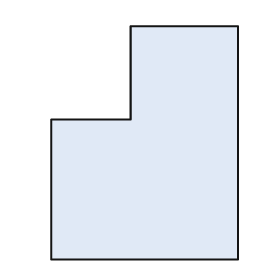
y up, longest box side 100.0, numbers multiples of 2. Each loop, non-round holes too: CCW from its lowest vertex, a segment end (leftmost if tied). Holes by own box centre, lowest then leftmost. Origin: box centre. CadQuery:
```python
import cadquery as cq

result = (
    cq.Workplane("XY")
    .moveTo(-40.0, -50.0)
    .lineTo(40.0, -50.0)
    .lineTo(40.0, 50.0)
    .lineTo(-6.0, 50.0)
    .lineTo(-6.0, 10.0)
    .lineTo(-40.0, 10.0)
    .close()
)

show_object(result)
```